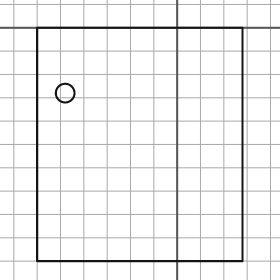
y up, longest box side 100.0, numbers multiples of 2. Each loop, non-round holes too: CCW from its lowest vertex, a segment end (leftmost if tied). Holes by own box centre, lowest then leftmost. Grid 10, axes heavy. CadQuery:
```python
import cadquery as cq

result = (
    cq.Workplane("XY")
    .moveTo(-60.0, -100.0)
    .lineTo(28.0, -100.0)
    .lineTo(28.0, 0.0)
    .lineTo(-60.0, 0.0)
    .close()
    .moveTo(-48.0, -28.0)
    .circle(4.0)
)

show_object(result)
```